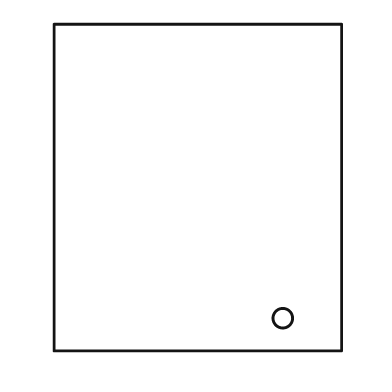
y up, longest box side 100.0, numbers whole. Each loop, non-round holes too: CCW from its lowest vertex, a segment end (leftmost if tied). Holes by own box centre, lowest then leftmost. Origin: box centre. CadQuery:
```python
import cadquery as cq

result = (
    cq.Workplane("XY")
    .moveTo(-44.0, -50.0)
    .lineTo(44.0, -50.0)
    .lineTo(44.0, 50.0)
    .lineTo(-44.0, 50.0)
    .close()
    .moveTo(26.0, -40.0)
    .circle(3.0)
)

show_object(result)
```